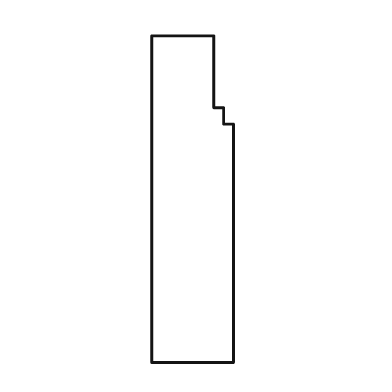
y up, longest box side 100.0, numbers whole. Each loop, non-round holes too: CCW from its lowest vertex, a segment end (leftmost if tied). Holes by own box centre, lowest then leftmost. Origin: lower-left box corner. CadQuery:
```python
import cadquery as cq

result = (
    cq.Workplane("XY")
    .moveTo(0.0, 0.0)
    .lineTo(25.0, 0.0)
    .lineTo(25.0, 73.0)
    .lineTo(22.0, 73.0)
    .lineTo(22.0, 78.0)
    .lineTo(19.0, 78.0)
    .lineTo(19.0, 100.0)
    .lineTo(0.0, 100.0)
    .close()
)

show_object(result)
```